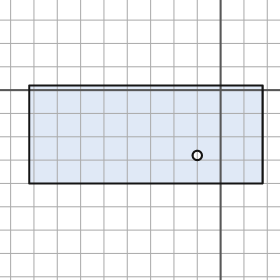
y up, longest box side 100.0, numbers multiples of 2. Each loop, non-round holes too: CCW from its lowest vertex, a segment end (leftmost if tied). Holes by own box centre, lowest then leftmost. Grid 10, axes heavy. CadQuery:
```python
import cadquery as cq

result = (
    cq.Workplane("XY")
    .moveTo(-82.0, -40.0)
    .lineTo(18.0, -40.0)
    .lineTo(18.0, 2.0)
    .lineTo(-82.0, 2.0)
    .close()
    .moveTo(-10.0, -28.0)
    .circle(2.0)
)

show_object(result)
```